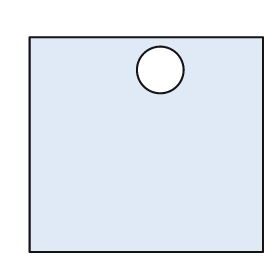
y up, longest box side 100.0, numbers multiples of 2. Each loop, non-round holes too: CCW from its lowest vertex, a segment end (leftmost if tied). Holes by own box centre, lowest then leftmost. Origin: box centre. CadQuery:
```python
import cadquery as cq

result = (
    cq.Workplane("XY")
    .moveTo(-50.0, -46.0)
    .lineTo(50.0, -46.0)
    .lineTo(50.0, 46.0)
    .lineTo(-50.0, 46.0)
    .close()
    .moveTo(6.0, 32.0)
    .circle(10.0)
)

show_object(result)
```